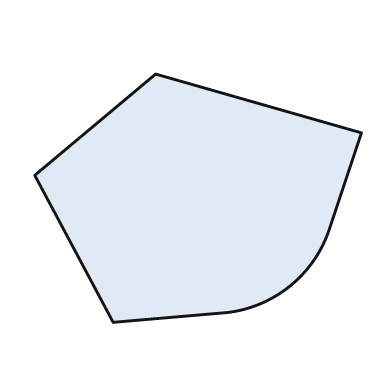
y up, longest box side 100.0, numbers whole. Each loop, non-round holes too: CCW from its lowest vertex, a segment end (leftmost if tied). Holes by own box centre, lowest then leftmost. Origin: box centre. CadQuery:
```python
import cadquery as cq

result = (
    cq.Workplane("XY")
    .moveTo(-26.0, -38.0)
    .lineTo(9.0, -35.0)
    .threePointArc((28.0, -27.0), (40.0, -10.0))
    .lineTo(50.0, 20.0)
    .lineTo(-13.0, 38.0)
    .lineTo(-50.0, 7.0)
    .close()
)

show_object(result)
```